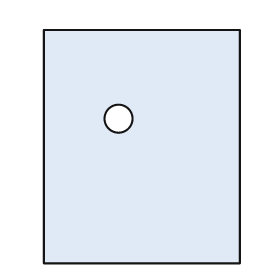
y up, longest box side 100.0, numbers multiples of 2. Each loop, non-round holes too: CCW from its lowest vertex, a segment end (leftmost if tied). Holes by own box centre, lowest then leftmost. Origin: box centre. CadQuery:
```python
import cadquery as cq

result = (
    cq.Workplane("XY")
    .moveTo(-42.0, -50.0)
    .lineTo(42.0, -50.0)
    .lineTo(42.0, 50.0)
    .lineTo(-42.0, 50.0)
    .close()
    .moveTo(-10.0, 12.0)
    .circle(6.0)
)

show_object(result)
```